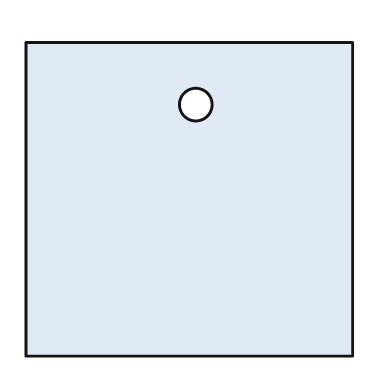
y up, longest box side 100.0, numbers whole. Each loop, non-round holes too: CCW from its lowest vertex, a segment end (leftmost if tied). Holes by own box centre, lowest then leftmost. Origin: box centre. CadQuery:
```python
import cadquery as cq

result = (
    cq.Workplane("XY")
    .moveTo(-50.0, -48.0)
    .lineTo(50.0, -48.0)
    .lineTo(50.0, 48.0)
    .lineTo(-50.0, 48.0)
    .close()
    .moveTo(2.0, 29.0)
    .circle(5.0)
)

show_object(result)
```